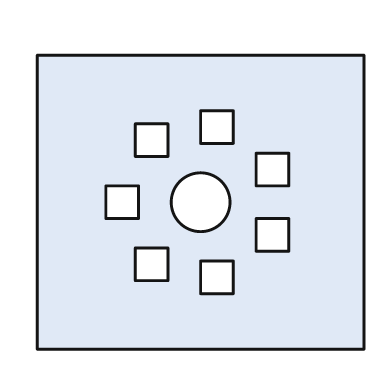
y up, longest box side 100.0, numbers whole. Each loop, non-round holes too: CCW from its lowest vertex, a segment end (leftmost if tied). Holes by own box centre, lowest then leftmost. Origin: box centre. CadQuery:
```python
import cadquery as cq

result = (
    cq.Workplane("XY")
    .moveTo(-50.0, -45.0)
    .lineTo(50.0, -45.0)
    .lineTo(50.0, 45.0)
    .lineTo(-50.0, 45.0)
    .close()
    .moveTo(0.0, -28.0)
    .lineTo(10.0, -28.0)
    .lineTo(10.0, -18.0)
    .lineTo(0.0, -18.0)
    .close()
    .moveTo(-20.0, -24.0)
    .lineTo(-10.0, -24.0)
    .lineTo(-10.0, -14.0)
    .lineTo(-20.0, -14.0)
    .close()
    .moveTo(17.0, -15.0)
    .lineTo(27.0, -15.0)
    .lineTo(27.0, -5.0)
    .lineTo(17.0, -5.0)
    .close()
    .moveTo(-29.0, -5.0)
    .lineTo(-19.0, -5.0)
    .lineTo(-19.0, 5.0)
    .lineTo(-29.0, 5.0)
    .close()
    .moveTo(0.0, 0.0)
    .circle(9.0)
    .moveTo(17.0, 5.0)
    .lineTo(27.0, 5.0)
    .lineTo(27.0, 15.0)
    .lineTo(17.0, 15.0)
    .close()
    .moveTo(-20.0, 14.0)
    .lineTo(-10.0, 14.0)
    .lineTo(-10.0, 24.0)
    .lineTo(-20.0, 24.0)
    .close()
    .moveTo(0.0, 18.0)
    .lineTo(10.0, 18.0)
    .lineTo(10.0, 28.0)
    .lineTo(0.0, 28.0)
    .close()
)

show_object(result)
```